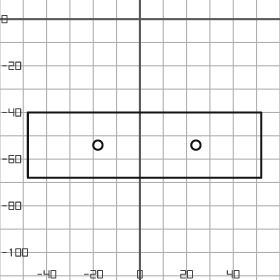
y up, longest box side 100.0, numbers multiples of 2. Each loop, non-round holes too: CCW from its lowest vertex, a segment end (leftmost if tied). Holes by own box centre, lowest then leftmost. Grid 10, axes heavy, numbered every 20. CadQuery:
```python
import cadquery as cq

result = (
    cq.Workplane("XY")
    .moveTo(-48.0, -68.0)
    .lineTo(52.0, -68.0)
    .lineTo(52.0, -40.0)
    .lineTo(-48.0, -40.0)
    .close()
    .moveTo(-18.0, -54.0)
    .circle(2.0)
    .moveTo(24.0, -54.0)
    .circle(2.0)
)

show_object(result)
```